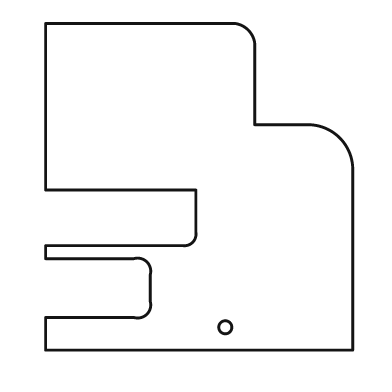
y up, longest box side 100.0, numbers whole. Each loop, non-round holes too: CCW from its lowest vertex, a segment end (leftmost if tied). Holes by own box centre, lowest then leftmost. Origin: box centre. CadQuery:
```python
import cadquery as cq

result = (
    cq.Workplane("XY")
    .moveTo(-47.0, -50.0)
    .lineTo(47.0, -50.0)
    .lineTo(47.0, 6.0)
    .threePointArc((43.0, 15.0), (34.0, 19.0))
    .lineTo(17.0, 19.0)
    .lineTo(17.0, 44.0)
    .threePointArc((15.0, 48.0), (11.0, 50.0))
    .lineTo(-47.0, 50.0)
    .lineTo(-47.0, -1.0)
    .lineTo(-1.0, -1.0)
    .lineTo(-1.0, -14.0)
    .threePointArc((-2.0, -17.0), (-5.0, -18.0))
    .lineTo(-47.0, -18.0)
    .lineTo(-47.0, -22.0)
    .lineTo(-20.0, -22.0)
    .threePointArc((-16.0, -23.0), (-15.0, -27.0))
    .lineTo(-15.0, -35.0)
    .threePointArc((-16.0, -39.0), (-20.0, -40.0))
    .lineTo(-47.0, -40.0)
    .close()
    .moveTo(8.0, -43.0)
    .circle(2.0)
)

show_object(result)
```